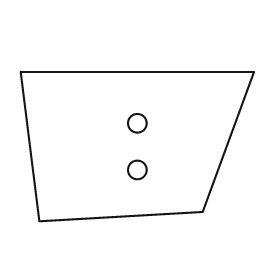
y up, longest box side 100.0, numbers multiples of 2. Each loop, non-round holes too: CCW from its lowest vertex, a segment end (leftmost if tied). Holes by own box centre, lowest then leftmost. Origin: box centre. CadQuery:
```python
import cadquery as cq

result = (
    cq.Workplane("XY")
    .moveTo(-42.0, -32.0)
    .lineTo(28.0, -28.0)
    .lineTo(50.0, 32.0)
    .lineTo(-50.0, 32.0)
    .close()
    .moveTo(0.0, -10.0)
    .circle(4.0)
    .moveTo(0.0, 10.0)
    .circle(4.0)
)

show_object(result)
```